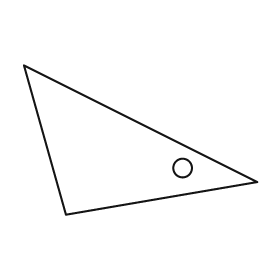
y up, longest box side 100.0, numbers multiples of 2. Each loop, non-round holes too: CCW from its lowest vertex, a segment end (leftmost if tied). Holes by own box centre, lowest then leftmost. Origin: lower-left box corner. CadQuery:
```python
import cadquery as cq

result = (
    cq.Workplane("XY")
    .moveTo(18.0, 0.0)
    .lineTo(100.0, 14.0)
    .lineTo(0.0, 64.0)
    .close()
    .moveTo(68.0, 20.0)
    .circle(4.0)
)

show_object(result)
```